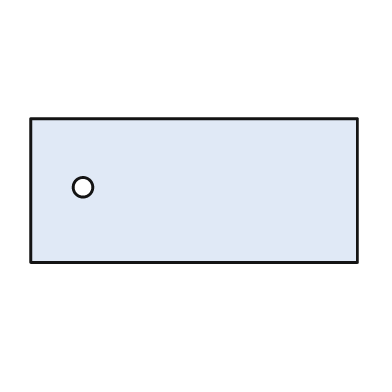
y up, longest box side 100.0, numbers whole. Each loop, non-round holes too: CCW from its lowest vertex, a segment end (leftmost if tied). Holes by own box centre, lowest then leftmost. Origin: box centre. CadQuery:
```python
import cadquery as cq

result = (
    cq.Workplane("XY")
    .moveTo(-50.0, -22.0)
    .lineTo(50.0, -22.0)
    .lineTo(50.0, 22.0)
    .lineTo(-50.0, 22.0)
    .close()
    .moveTo(-34.0, 1.0)
    .circle(3.0)
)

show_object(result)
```